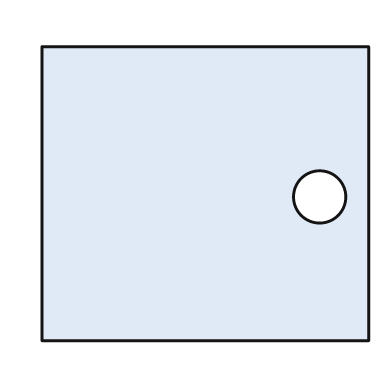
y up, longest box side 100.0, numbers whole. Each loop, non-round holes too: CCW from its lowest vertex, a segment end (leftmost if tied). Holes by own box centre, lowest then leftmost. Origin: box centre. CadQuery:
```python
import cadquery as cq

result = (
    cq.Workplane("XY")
    .moveTo(-50.0, -45.0)
    .lineTo(50.0, -45.0)
    .lineTo(50.0, 45.0)
    .lineTo(-50.0, 45.0)
    .close()
    .moveTo(35.0, -1.0)
    .circle(8.0)
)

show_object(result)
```